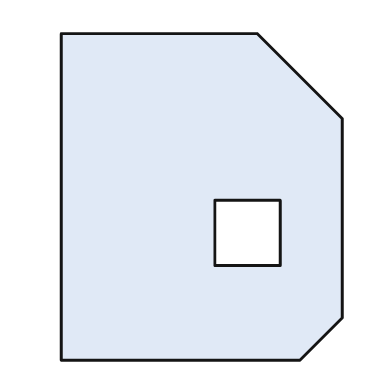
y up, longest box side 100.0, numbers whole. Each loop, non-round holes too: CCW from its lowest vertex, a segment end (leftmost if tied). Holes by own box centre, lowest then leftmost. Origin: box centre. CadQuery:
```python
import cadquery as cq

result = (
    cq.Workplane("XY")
    .moveTo(-43.0, -50.0)
    .lineTo(30.0, -50.0)
    .lineTo(43.0, -37.0)
    .lineTo(43.0, 24.0)
    .lineTo(17.0, 50.0)
    .lineTo(-43.0, 50.0)
    .close()
    .moveTo(4.0, -21.0)
    .lineTo(24.0, -21.0)
    .lineTo(24.0, -1.0)
    .lineTo(4.0, -1.0)
    .close()
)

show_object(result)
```